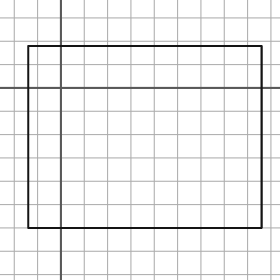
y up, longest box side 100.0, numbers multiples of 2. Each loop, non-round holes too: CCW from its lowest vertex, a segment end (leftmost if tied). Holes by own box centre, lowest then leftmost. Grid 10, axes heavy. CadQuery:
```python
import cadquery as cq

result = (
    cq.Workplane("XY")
    .moveTo(-14.0, -60.0)
    .lineTo(86.0, -60.0)
    .lineTo(86.0, 18.0)
    .lineTo(-14.0, 18.0)
    .close()
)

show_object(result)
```